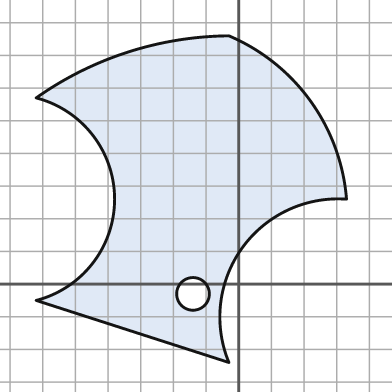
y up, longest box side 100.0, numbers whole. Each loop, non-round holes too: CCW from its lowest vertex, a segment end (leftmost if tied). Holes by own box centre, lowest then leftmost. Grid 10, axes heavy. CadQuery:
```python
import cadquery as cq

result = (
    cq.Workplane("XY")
    .moveTo(-3.0, -24.0)
    .threePointArc((1.0, 11.0), (33.0, 26.0))
    .threePointArc((22.0, 56.0), (-3.0, 76.0))
    .threePointArc((-34.0, 71.0), (-62.0, 57.0))
    .threePointArc((-38.0, 26.0), (-62.0, -5.0))
    .close()
    .moveTo(-14.0, -3.0)
    .circle(5.0)
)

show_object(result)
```